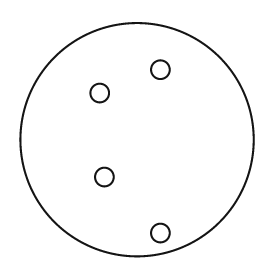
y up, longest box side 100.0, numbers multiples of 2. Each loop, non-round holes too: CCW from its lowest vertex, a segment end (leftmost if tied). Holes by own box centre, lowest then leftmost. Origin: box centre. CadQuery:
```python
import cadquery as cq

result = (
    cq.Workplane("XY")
    .moveTo(0.0, 0.0)
    .circle(50.0)
    .moveTo(10.0, -40.0)
    .circle(4.0)
    .moveTo(-14.0, -16.0)
    .circle(4.0)
    .moveTo(-16.0, 20.0)
    .circle(4.0)
    .moveTo(10.0, 30.0)
    .circle(4.0)
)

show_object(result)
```